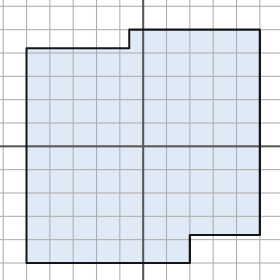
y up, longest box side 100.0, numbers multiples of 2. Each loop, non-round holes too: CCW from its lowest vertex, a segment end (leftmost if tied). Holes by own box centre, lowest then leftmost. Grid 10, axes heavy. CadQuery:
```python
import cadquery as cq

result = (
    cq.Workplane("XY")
    .moveTo(-50.0, -50.0)
    .lineTo(20.0, -50.0)
    .lineTo(20.0, -38.0)
    .lineTo(50.0, -38.0)
    .lineTo(50.0, 50.0)
    .lineTo(-6.0, 50.0)
    .lineTo(-6.0, 42.0)
    .lineTo(-50.0, 42.0)
    .close()
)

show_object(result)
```